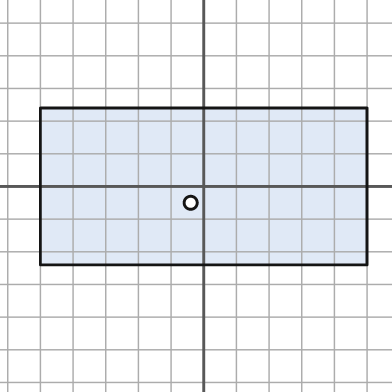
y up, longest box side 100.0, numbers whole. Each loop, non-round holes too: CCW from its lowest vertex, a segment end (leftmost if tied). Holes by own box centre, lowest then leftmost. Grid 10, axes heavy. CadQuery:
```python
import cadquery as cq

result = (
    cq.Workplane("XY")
    .moveTo(-50.0, -24.0)
    .lineTo(50.0, -24.0)
    .lineTo(50.0, 24.0)
    .lineTo(-50.0, 24.0)
    .close()
    .moveTo(-4.0, -5.0)
    .circle(2.0)
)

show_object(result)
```